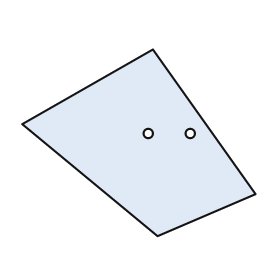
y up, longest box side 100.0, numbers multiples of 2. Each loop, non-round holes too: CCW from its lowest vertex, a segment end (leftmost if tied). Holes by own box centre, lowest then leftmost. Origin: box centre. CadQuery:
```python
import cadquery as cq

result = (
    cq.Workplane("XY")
    .moveTo(8.0, -40.0)
    .lineTo(50.0, -22.0)
    .lineTo(6.0, 40.0)
    .lineTo(-50.0, 8.0)
    .close()
    .moveTo(4.0, 4.0)
    .circle(2.0)
    .moveTo(22.0, 4.0)
    .circle(2.0)
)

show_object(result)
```